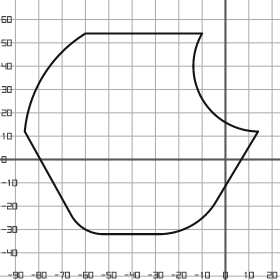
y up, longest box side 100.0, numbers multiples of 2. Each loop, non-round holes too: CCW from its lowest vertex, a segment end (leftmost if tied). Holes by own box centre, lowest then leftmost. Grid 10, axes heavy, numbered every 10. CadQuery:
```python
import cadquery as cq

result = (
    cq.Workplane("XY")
    .moveTo(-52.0, -32.0)
    .lineTo(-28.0, -32.0)
    .threePointArc((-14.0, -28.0), (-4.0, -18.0))
    .lineTo(14.0, 12.0)
    .threePointArc((-10.0, 26.0), (-10.0, 54.0))
    .lineTo(-60.0, 54.0)
    .threePointArc((-78.0, 36.0), (-86.0, 12.0))
    .lineTo(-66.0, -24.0)
    .threePointArc((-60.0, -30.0), (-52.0, -32.0))
    .close()
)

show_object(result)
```